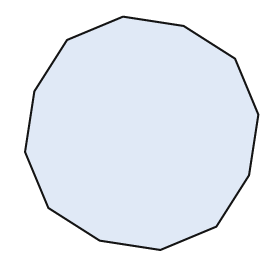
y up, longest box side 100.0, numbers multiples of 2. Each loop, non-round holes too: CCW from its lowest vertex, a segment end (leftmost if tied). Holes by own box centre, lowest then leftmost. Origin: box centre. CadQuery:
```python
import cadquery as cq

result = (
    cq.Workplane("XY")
    .moveTo(8.0, -50.0)
    .lineTo(32.0, -40.0)
    .lineTo(46.0, -18.0)
    .lineTo(50.0, 8.0)
    .lineTo(40.0, 32.0)
    .lineTo(18.0, 46.0)
    .lineTo(-8.0, 50.0)
    .lineTo(-32.0, 40.0)
    .lineTo(-46.0, 18.0)
    .lineTo(-50.0, -8.0)
    .lineTo(-40.0, -32.0)
    .lineTo(-18.0, -46.0)
    .close()
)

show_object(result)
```